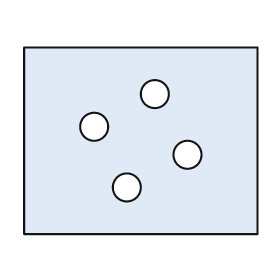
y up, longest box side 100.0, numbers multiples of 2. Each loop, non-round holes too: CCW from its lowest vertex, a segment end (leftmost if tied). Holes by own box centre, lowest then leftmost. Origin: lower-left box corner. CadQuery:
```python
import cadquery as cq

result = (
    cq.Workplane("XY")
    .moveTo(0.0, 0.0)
    .lineTo(100.0, 0.0)
    .lineTo(100.0, 80.0)
    .lineTo(0.0, 80.0)
    .close()
    .moveTo(44.0, 20.0)
    .circle(6.0)
    .moveTo(70.0, 34.0)
    .circle(6.0)
    .moveTo(30.0, 46.0)
    .circle(6.0)
    .moveTo(56.0, 60.0)
    .circle(6.0)
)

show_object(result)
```